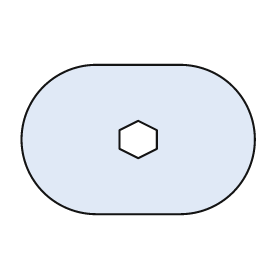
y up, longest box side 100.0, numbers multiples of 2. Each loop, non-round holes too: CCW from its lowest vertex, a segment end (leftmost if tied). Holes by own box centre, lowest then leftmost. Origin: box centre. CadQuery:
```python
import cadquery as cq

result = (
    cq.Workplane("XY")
    .moveTo(-18.0, -32.0)
    .lineTo(18.0, -32.0)
    .threePointArc((50.0, 0.0), (18.0, 32.0))
    .lineTo(-18.0, 32.0)
    .threePointArc((-50.0, 0.0), (-18.0, -32.0))
    .close()
    .moveTo(0.0, -8.0)
    .lineTo(8.0, -4.0)
    .lineTo(8.0, 4.0)
    .lineTo(0.0, 8.0)
    .lineTo(-8.0, 4.0)
    .lineTo(-8.0, -4.0)
    .close()
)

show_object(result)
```